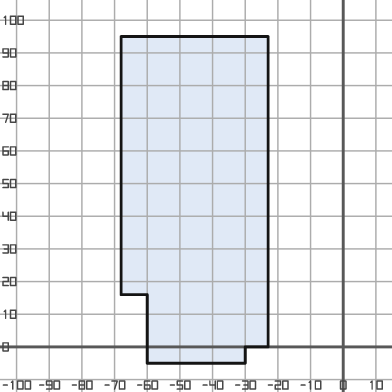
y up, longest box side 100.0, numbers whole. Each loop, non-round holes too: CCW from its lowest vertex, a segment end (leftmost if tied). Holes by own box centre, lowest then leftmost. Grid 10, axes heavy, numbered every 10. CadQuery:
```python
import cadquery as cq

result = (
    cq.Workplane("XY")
    .moveTo(-60.0, -5.0)
    .lineTo(-30.0, -5.0)
    .lineTo(-30.0, 0.0)
    .lineTo(-23.0, 0.0)
    .lineTo(-23.0, 95.0)
    .lineTo(-68.0, 95.0)
    .lineTo(-68.0, 16.0)
    .lineTo(-60.0, 16.0)
    .close()
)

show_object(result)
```